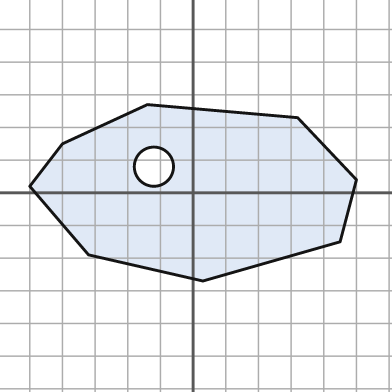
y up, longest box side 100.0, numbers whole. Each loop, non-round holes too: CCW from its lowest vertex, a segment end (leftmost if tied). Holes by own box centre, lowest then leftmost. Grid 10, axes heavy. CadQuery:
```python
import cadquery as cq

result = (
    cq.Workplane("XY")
    .moveTo(3.0, -27.0)
    .lineTo(45.0, -15.0)
    .lineTo(50.0, 4.0)
    .lineTo(32.0, 23.0)
    .lineTo(-14.0, 27.0)
    .lineTo(-40.0, 15.0)
    .lineTo(-50.0, 2.0)
    .lineTo(-32.0, -19.0)
    .close()
    .moveTo(-12.0, 8.0)
    .circle(6.0)
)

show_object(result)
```